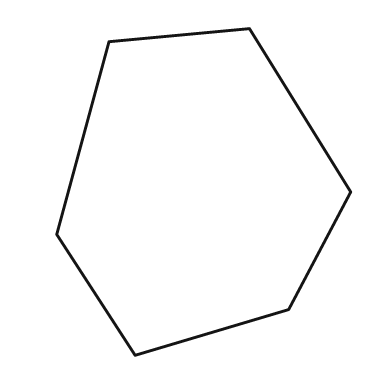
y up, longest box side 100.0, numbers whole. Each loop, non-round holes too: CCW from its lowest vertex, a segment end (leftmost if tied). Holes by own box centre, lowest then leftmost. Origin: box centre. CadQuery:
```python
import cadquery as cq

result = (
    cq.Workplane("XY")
    .moveTo(-21.0, -50.0)
    .lineTo(26.0, -36.0)
    .lineTo(45.0, 0.0)
    .lineTo(14.0, 50.0)
    .lineTo(-29.0, 46.0)
    .lineTo(-45.0, -13.0)
    .close()
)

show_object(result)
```